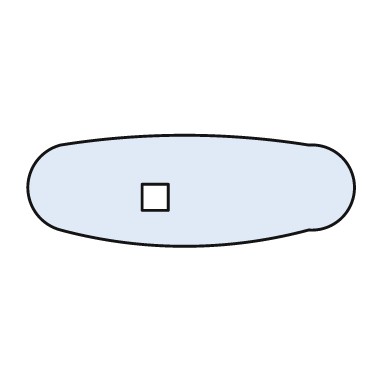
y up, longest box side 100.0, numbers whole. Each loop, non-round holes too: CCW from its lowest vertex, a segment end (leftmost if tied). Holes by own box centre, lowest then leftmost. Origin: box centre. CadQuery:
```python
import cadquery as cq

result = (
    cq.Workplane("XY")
    .moveTo(-40.0, -12.0)
    .threePointArc((-2.0, -17.0), (36.0, -12.0))
    .threePointArc((50.0, 1.0), (36.0, 14.0))
    .threePointArc((-2.0, 17.0), (-40.0, 14.0))
    .threePointArc((-50.0, 1.0), (-40.0, -12.0))
    .close()
    .moveTo(-15.0, -6.0)
    .lineTo(-7.0, -6.0)
    .lineTo(-7.0, 2.0)
    .lineTo(-15.0, 2.0)
    .close()
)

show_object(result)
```